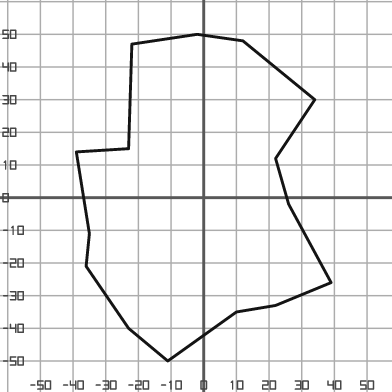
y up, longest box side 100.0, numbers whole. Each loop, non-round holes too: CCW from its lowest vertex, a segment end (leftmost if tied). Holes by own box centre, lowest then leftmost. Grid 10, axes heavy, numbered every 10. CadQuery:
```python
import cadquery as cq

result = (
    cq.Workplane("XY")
    .moveTo(-11.0, -50.0)
    .lineTo(10.0, -35.0)
    .lineTo(22.0, -33.0)
    .lineTo(39.0, -26.0)
    .lineTo(26.0, -2.0)
    .lineTo(22.0, 12.0)
    .lineTo(34.0, 30.0)
    .lineTo(12.0, 48.0)
    .lineTo(-2.0, 50.0)
    .lineTo(-22.0, 47.0)
    .lineTo(-23.0, 15.0)
    .lineTo(-39.0, 14.0)
    .lineTo(-35.0, -11.0)
    .lineTo(-36.0, -21.0)
    .lineTo(-23.0, -40.0)
    .close()
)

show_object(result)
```